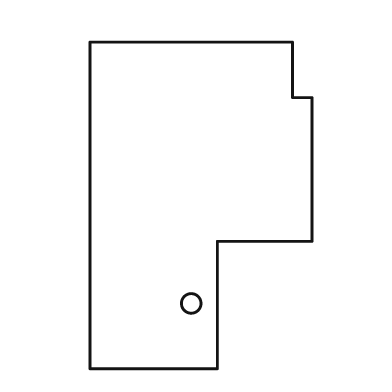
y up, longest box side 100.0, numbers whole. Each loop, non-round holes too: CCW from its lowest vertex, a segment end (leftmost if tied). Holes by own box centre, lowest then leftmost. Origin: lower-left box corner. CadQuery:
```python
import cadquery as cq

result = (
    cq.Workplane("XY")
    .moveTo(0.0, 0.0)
    .lineTo(39.0, 0.0)
    .lineTo(39.0, 39.0)
    .lineTo(68.0, 39.0)
    .lineTo(68.0, 83.0)
    .lineTo(62.0, 83.0)
    .lineTo(62.0, 100.0)
    .lineTo(0.0, 100.0)
    .close()
    .moveTo(31.0, 20.0)
    .circle(3.0)
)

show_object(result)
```